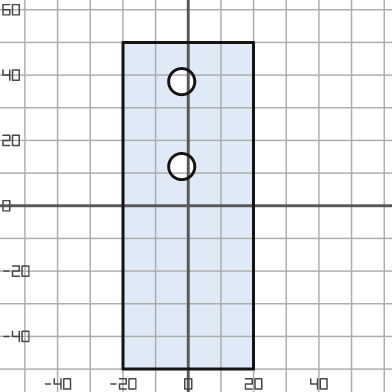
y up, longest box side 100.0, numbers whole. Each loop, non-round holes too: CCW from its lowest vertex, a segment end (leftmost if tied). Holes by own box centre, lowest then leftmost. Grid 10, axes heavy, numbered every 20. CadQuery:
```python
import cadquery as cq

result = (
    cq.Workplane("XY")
    .moveTo(-20.0, -50.0)
    .lineTo(20.0, -50.0)
    .lineTo(20.0, 50.0)
    .lineTo(-20.0, 50.0)
    .close()
    .moveTo(-2.0, 12.0)
    .circle(4.0)
    .moveTo(-2.0, 38.0)
    .circle(4.0)
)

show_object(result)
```